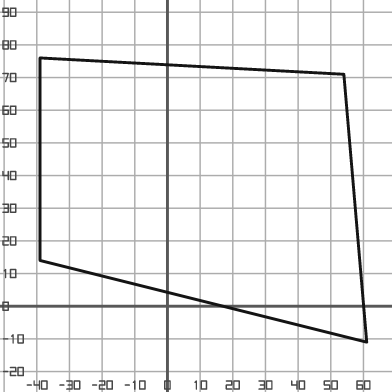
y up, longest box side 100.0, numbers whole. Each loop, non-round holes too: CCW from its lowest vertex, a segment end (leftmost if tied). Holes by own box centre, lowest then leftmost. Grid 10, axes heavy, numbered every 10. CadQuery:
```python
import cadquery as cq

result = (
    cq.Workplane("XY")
    .moveTo(61.0, -11.0)
    .lineTo(54.0, 71.0)
    .lineTo(-39.0, 76.0)
    .lineTo(-39.0, 14.0)
    .close()
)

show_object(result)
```